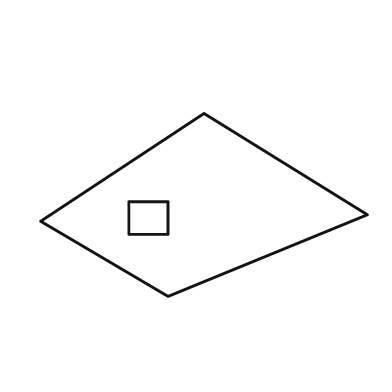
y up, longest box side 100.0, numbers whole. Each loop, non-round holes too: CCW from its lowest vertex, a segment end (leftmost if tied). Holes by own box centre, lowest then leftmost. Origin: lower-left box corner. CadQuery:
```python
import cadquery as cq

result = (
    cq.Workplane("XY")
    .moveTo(39.0, 0.0)
    .lineTo(100.0, 25.0)
    .lineTo(50.0, 56.0)
    .lineTo(0.0, 23.0)
    .close()
    .moveTo(27.0, 19.0)
    .lineTo(39.0, 19.0)
    .lineTo(39.0, 29.0)
    .lineTo(27.0, 29.0)
    .close()
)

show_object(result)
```